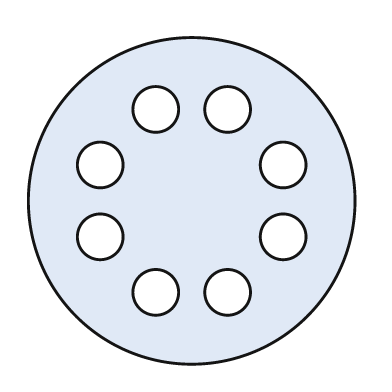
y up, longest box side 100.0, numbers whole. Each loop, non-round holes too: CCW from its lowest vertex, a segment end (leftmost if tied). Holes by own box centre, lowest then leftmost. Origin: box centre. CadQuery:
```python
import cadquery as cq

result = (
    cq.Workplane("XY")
    .moveTo(0.0, 0.0)
    .circle(50.0)
    .moveTo(-11.0, -28.0)
    .circle(7.0)
    .moveTo(11.0, -28.0)
    .circle(7.0)
    .moveTo(-28.0, -11.0)
    .circle(7.0)
    .moveTo(28.0, -11.0)
    .circle(7.0)
    .moveTo(-28.0, 11.0)
    .circle(7.0)
    .moveTo(28.0, 11.0)
    .circle(7.0)
    .moveTo(-11.0, 28.0)
    .circle(7.0)
    .moveTo(11.0, 28.0)
    .circle(7.0)
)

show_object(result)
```